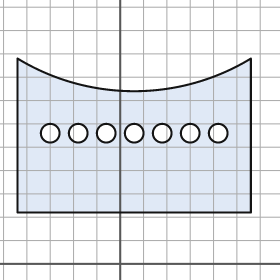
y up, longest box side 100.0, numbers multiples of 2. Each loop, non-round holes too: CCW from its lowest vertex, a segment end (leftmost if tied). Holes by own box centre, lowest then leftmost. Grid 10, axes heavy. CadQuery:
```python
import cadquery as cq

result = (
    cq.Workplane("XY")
    .moveTo(-44.0, 22.0)
    .lineTo(56.0, 22.0)
    .lineTo(56.0, 88.0)
    .threePointArc((6.0, 74.0), (-44.0, 88.0))
    .close()
    .moveTo(-30.0, 56.0)
    .circle(4.0)
    .moveTo(-18.0, 56.0)
    .circle(4.0)
    .moveTo(-6.0, 56.0)
    .circle(4.0)
    .moveTo(6.0, 56.0)
    .circle(4.0)
    .moveTo(18.0, 56.0)
    .circle(4.0)
    .moveTo(30.0, 56.0)
    .circle(4.0)
    .moveTo(42.0, 56.0)
    .circle(4.0)
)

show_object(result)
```